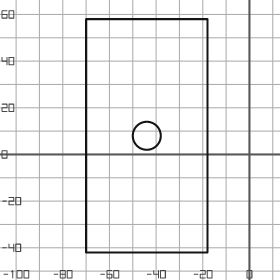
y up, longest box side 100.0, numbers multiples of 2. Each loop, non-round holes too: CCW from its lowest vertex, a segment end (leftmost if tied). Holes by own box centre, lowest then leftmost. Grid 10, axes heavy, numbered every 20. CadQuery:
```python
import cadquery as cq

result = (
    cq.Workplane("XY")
    .moveTo(-70.0, -42.0)
    .lineTo(-18.0, -42.0)
    .lineTo(-18.0, 58.0)
    .lineTo(-70.0, 58.0)
    .close()
    .moveTo(-44.0, 8.0)
    .circle(6.0)
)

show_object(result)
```